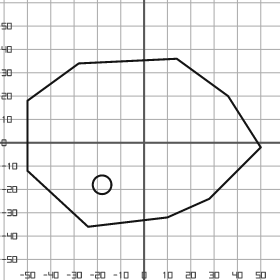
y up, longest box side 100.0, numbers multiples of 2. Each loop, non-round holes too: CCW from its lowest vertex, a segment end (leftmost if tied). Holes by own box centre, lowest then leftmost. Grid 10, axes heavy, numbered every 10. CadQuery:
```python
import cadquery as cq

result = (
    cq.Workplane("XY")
    .moveTo(-24.0, -36.0)
    .lineTo(10.0, -32.0)
    .lineTo(28.0, -24.0)
    .lineTo(50.0, -2.0)
    .lineTo(36.0, 20.0)
    .lineTo(14.0, 36.0)
    .lineTo(-28.0, 34.0)
    .lineTo(-50.0, 18.0)
    .lineTo(-50.0, -12.0)
    .close()
    .moveTo(-18.0, -18.0)
    .circle(4.0)
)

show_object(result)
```